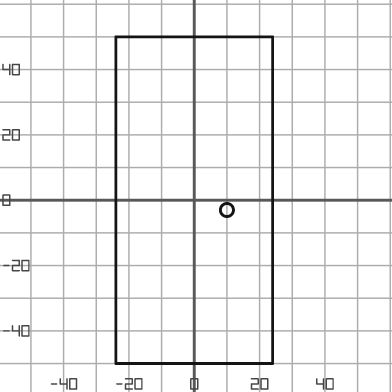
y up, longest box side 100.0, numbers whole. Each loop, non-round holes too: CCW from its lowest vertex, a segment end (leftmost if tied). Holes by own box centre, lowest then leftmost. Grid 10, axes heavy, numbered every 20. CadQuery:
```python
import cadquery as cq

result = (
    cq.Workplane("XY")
    .moveTo(-24.0, -50.0)
    .lineTo(24.0, -50.0)
    .lineTo(24.0, 50.0)
    .lineTo(-24.0, 50.0)
    .close()
    .moveTo(10.0, -3.0)
    .circle(2.0)
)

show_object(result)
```